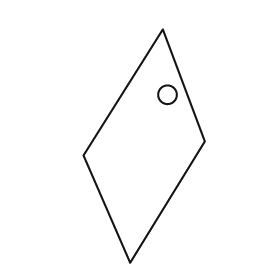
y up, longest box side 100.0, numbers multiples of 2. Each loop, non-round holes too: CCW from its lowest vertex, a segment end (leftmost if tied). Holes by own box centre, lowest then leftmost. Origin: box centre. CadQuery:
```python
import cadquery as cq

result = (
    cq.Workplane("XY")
    .moveTo(-6.0, -50.0)
    .lineTo(26.0, 2.0)
    .lineTo(8.0, 50.0)
    .lineTo(-26.0, -4.0)
    .close()
    .moveTo(10.0, 22.0)
    .circle(4.0)
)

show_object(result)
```